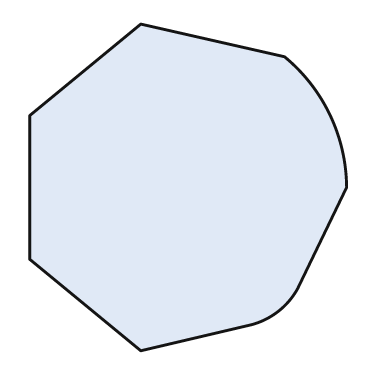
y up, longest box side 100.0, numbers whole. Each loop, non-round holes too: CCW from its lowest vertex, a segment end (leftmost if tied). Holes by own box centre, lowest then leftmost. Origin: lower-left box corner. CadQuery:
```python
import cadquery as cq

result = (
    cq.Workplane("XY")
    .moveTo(34.0, 0.0)
    .lineTo(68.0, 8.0)
    .threePointArc((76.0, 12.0), (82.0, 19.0))
    .lineTo(97.0, 50.0)
    .threePointArc((92.0, 72.0), (78.0, 90.0))
    .lineTo(34.0, 100.0)
    .lineTo(0.0, 72.0)
    .lineTo(0.0, 28.0)
    .close()
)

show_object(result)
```